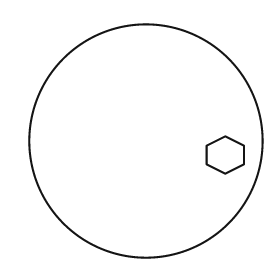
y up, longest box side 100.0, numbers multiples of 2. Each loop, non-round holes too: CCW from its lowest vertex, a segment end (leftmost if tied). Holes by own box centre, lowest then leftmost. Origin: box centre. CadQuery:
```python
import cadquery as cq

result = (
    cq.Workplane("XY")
    .moveTo(0.0, 0.0)
    .circle(50.0)
    .moveTo(34.0, -14.0)
    .lineTo(42.0, -10.0)
    .lineTo(42.0, -2.0)
    .lineTo(34.0, 2.0)
    .lineTo(26.0, -2.0)
    .lineTo(26.0, -10.0)
    .close()
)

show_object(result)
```